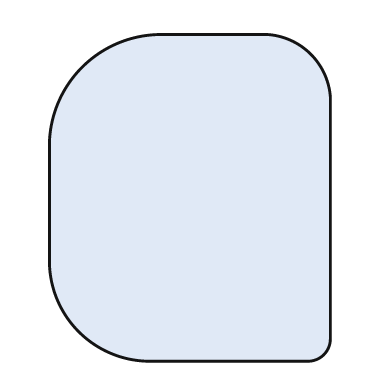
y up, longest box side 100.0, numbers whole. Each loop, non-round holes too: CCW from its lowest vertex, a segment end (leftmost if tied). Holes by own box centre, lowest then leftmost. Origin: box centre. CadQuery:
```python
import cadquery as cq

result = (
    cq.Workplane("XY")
    .moveTo(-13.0, -50.0)
    .lineTo(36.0, -50.0)
    .threePointArc((41.0, -48.0), (43.0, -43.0))
    .lineTo(43.0, 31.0)
    .threePointArc((37.0, 44.0), (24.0, 50.0))
    .lineTo(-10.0, 50.0)
    .threePointArc((-33.0, 40.0), (-43.0, 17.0))
    .lineTo(-43.0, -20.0)
    .threePointArc((-34.0, -41.0), (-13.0, -50.0))
    .close()
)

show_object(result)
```